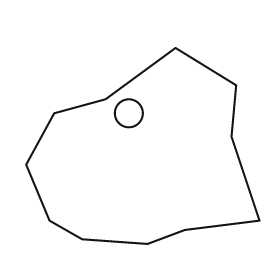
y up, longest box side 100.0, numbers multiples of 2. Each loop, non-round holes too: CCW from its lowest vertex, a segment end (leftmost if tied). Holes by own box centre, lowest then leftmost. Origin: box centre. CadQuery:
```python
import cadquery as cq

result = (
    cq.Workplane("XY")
    .moveTo(2.0, -42.0)
    .lineTo(18.0, -36.0)
    .lineTo(50.0, -32.0)
    .lineTo(38.0, 4.0)
    .lineTo(40.0, 26.0)
    .lineTo(14.0, 42.0)
    .lineTo(-16.0, 20.0)
    .lineTo(-38.0, 14.0)
    .lineTo(-50.0, -8.0)
    .lineTo(-40.0, -32.0)
    .lineTo(-26.0, -40.0)
    .close()
    .moveTo(-6.0, 14.0)
    .circle(6.0)
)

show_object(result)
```